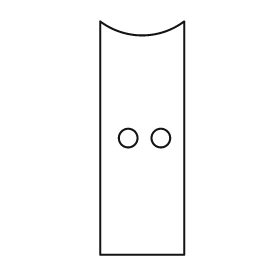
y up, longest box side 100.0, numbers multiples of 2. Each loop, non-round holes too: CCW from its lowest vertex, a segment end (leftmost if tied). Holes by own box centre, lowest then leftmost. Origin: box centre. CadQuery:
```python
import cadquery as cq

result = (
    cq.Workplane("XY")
    .moveTo(-18.0, -50.0)
    .lineTo(18.0, -50.0)
    .lineTo(18.0, 50.0)
    .threePointArc((0.0, 44.0), (-18.0, 50.0))
    .close()
    .moveTo(-6.0, 0.0)
    .circle(4.0)
    .moveTo(8.0, 0.0)
    .circle(4.0)
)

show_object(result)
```